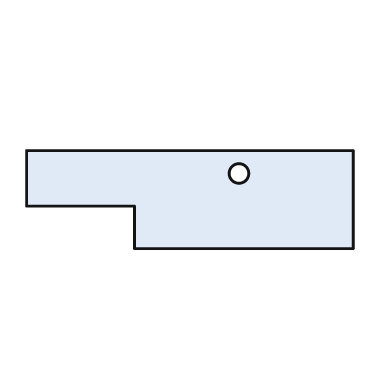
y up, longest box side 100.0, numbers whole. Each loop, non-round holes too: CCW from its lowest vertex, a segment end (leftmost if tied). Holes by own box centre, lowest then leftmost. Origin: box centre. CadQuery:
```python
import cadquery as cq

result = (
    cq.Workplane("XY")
    .moveTo(-17.0, -15.0)
    .lineTo(50.0, -15.0)
    .lineTo(50.0, 15.0)
    .lineTo(-50.0, 15.0)
    .lineTo(-50.0, -2.0)
    .lineTo(-17.0, -2.0)
    .close()
    .moveTo(15.0, 8.0)
    .circle(3.0)
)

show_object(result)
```